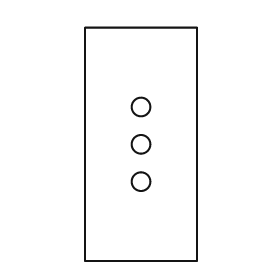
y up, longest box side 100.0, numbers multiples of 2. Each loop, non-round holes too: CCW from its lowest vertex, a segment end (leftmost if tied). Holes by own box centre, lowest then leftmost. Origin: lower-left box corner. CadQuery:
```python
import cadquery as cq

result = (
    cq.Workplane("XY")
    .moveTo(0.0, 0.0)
    .lineTo(48.0, 0.0)
    .lineTo(48.0, 100.0)
    .lineTo(0.0, 100.0)
    .close()
    .moveTo(24.0, 34.0)
    .circle(4.0)
    .moveTo(24.0, 50.0)
    .circle(4.0)
    .moveTo(24.0, 66.0)
    .circle(4.0)
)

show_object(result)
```